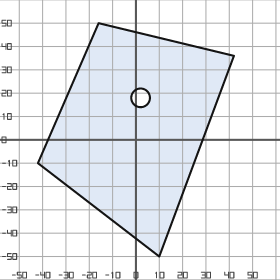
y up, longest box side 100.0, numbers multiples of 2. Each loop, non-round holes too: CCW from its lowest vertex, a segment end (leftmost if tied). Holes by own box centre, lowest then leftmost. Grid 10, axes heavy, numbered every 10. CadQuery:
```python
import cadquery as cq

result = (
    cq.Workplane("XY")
    .moveTo(10.0, -50.0)
    .lineTo(42.0, 36.0)
    .lineTo(-16.0, 50.0)
    .lineTo(-42.0, -10.0)
    .close()
    .moveTo(2.0, 18.0)
    .circle(4.0)
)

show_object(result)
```